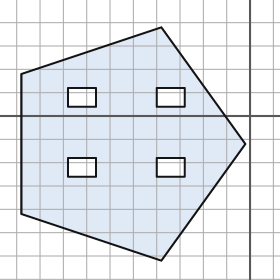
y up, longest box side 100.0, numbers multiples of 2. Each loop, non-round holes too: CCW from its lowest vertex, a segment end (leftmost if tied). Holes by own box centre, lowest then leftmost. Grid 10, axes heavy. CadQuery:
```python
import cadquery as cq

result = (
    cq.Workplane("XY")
    .moveTo(-38.0, -62.0)
    .lineTo(-2.0, -12.0)
    .lineTo(-38.0, 38.0)
    .lineTo(-98.0, 18.0)
    .lineTo(-98.0, -42.0)
    .close()
    .moveTo(-78.0, -26.0)
    .lineTo(-66.0, -26.0)
    .lineTo(-66.0, -18.0)
    .lineTo(-78.0, -18.0)
    .close()
    .moveTo(-40.0, -26.0)
    .lineTo(-28.0, -26.0)
    .lineTo(-28.0, -18.0)
    .lineTo(-40.0, -18.0)
    .close()
    .moveTo(-78.0, 4.0)
    .lineTo(-66.0, 4.0)
    .lineTo(-66.0, 12.0)
    .lineTo(-78.0, 12.0)
    .close()
    .moveTo(-40.0, 4.0)
    .lineTo(-28.0, 4.0)
    .lineTo(-28.0, 12.0)
    .lineTo(-40.0, 12.0)
    .close()
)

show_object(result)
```